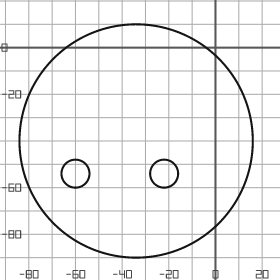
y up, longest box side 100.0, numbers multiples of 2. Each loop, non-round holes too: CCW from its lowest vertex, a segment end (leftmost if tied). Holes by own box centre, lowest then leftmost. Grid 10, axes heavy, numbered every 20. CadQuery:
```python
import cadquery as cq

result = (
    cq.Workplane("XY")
    .moveTo(-34.0, -40.0)
    .circle(50.0)
    .moveTo(-60.0, -54.0)
    .circle(6.0)
    .moveTo(-22.0, -54.0)
    .circle(6.0)
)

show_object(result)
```